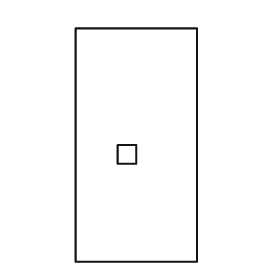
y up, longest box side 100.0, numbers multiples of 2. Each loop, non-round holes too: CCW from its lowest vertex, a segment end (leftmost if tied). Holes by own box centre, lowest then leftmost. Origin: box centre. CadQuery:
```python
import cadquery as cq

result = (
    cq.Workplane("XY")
    .moveTo(-26.0, -50.0)
    .lineTo(26.0, -50.0)
    .lineTo(26.0, 50.0)
    .lineTo(-26.0, 50.0)
    .close()
    .moveTo(-8.0, -8.0)
    .lineTo(0.0, -8.0)
    .lineTo(0.0, 0.0)
    .lineTo(-8.0, 0.0)
    .close()
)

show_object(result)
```